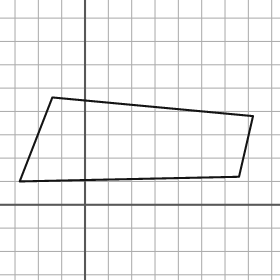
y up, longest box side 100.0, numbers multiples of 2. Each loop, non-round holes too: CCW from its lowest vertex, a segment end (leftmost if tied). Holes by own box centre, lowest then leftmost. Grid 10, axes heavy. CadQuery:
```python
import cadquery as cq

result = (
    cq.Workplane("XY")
    .moveTo(-28.0, 10.0)
    .lineTo(66.0, 12.0)
    .lineTo(72.0, 38.0)
    .lineTo(-14.0, 46.0)
    .close()
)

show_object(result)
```